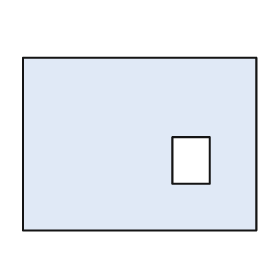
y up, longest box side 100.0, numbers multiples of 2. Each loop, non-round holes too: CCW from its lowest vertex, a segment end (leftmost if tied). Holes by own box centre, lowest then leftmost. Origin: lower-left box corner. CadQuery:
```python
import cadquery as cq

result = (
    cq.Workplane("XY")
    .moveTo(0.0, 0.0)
    .lineTo(100.0, 0.0)
    .lineTo(100.0, 74.0)
    .lineTo(0.0, 74.0)
    .close()
    .moveTo(64.0, 20.0)
    .lineTo(80.0, 20.0)
    .lineTo(80.0, 40.0)
    .lineTo(64.0, 40.0)
    .close()
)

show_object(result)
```